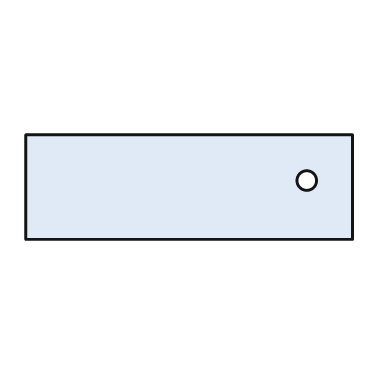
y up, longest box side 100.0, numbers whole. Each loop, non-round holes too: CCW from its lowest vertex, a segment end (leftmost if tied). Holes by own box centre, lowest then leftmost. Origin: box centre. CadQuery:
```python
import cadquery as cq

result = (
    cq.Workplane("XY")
    .moveTo(-50.0, -16.0)
    .lineTo(50.0, -16.0)
    .lineTo(50.0, 16.0)
    .lineTo(-50.0, 16.0)
    .close()
    .moveTo(36.0, 2.0)
    .circle(3.0)
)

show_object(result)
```